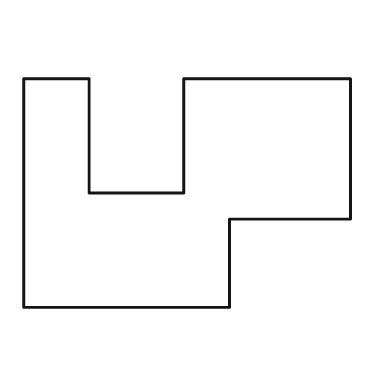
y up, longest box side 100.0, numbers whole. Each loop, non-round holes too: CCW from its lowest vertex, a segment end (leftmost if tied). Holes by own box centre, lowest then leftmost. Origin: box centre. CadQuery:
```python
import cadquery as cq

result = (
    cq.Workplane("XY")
    .moveTo(-50.0, -35.0)
    .lineTo(13.0, -35.0)
    .lineTo(13.0, -8.0)
    .lineTo(50.0, -8.0)
    .lineTo(50.0, 35.0)
    .lineTo(-1.0, 35.0)
    .lineTo(-1.0, 0.0)
    .lineTo(-30.0, 0.0)
    .lineTo(-30.0, 35.0)
    .lineTo(-50.0, 35.0)
    .close()
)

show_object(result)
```